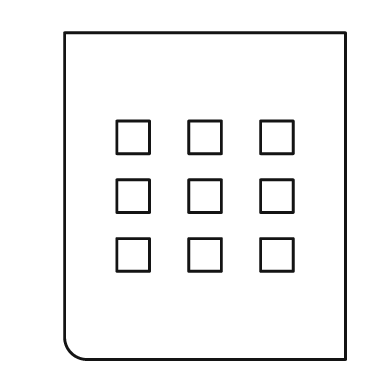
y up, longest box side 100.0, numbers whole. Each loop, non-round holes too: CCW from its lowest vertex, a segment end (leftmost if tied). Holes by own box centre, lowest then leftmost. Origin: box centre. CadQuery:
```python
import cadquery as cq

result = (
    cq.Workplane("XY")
    .moveTo(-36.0, -50.0)
    .lineTo(43.0, -50.0)
    .lineTo(43.0, 50.0)
    .lineTo(-43.0, 50.0)
    .lineTo(-43.0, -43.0)
    .threePointArc((-41.0, -48.0), (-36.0, -50.0))
    .close()
    .moveTo(-27.0, -23.0)
    .lineTo(-17.0, -23.0)
    .lineTo(-17.0, -13.0)
    .lineTo(-27.0, -13.0)
    .close()
    .moveTo(-5.0, -23.0)
    .lineTo(5.0, -23.0)
    .lineTo(5.0, -13.0)
    .lineTo(-5.0, -13.0)
    .close()
    .moveTo(17.0, -23.0)
    .lineTo(27.0, -23.0)
    .lineTo(27.0, -13.0)
    .lineTo(17.0, -13.0)
    .close()
    .moveTo(-27.0, -5.0)
    .lineTo(-17.0, -5.0)
    .lineTo(-17.0, 5.0)
    .lineTo(-27.0, 5.0)
    .close()
    .moveTo(-5.0, -5.0)
    .lineTo(5.0, -5.0)
    .lineTo(5.0, 5.0)
    .lineTo(-5.0, 5.0)
    .close()
    .moveTo(17.0, -5.0)
    .lineTo(27.0, -5.0)
    .lineTo(27.0, 5.0)
    .lineTo(17.0, 5.0)
    .close()
    .moveTo(-27.0, 13.0)
    .lineTo(-17.0, 13.0)
    .lineTo(-17.0, 23.0)
    .lineTo(-27.0, 23.0)
    .close()
    .moveTo(-5.0, 13.0)
    .lineTo(5.0, 13.0)
    .lineTo(5.0, 23.0)
    .lineTo(-5.0, 23.0)
    .close()
    .moveTo(17.0, 13.0)
    .lineTo(27.0, 13.0)
    .lineTo(27.0, 23.0)
    .lineTo(17.0, 23.0)
    .close()
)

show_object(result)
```